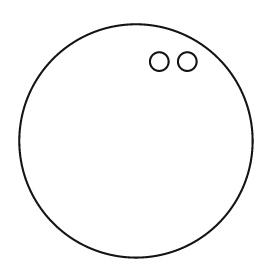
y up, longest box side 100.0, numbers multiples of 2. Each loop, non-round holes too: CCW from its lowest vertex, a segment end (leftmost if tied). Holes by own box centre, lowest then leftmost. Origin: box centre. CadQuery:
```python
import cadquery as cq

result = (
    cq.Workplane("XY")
    .moveTo(0.0, 0.0)
    .circle(50.0)
    .moveTo(10.0, 34.0)
    .circle(4.0)
    .moveTo(22.0, 34.0)
    .circle(4.0)
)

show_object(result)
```